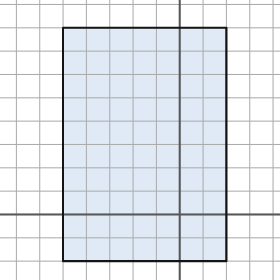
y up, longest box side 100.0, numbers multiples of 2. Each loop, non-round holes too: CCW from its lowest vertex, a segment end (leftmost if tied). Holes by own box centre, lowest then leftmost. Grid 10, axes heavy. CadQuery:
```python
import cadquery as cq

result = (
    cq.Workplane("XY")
    .moveTo(-50.0, -20.0)
    .lineTo(20.0, -20.0)
    .lineTo(20.0, 80.0)
    .lineTo(-50.0, 80.0)
    .close()
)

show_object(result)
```